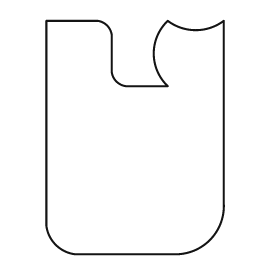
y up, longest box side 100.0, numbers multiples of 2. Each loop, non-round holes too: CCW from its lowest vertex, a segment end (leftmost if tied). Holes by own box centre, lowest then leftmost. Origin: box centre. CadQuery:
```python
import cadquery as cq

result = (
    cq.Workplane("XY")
    .moveTo(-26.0, -50.0)
    .lineTo(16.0, -50.0)
    .threePointArc((32.0, -44.0), (38.0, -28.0))
    .lineTo(38.0, 50.0)
    .threePointArc((26.0, 46.0), (14.0, 50.0))
    .threePointArc((8.0, 36.0), (14.0, 22.0))
    .lineTo(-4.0, 22.0)
    .threePointArc((-8.0, 24.0), (-10.0, 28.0))
    .lineTo(-10.0, 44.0)
    .threePointArc((-12.0, 48.0), (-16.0, 50.0))
    .lineTo(-38.0, 50.0)
    .lineTo(-38.0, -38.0)
    .threePointArc((-34.0, -46.0), (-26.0, -50.0))
    .close()
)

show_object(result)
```